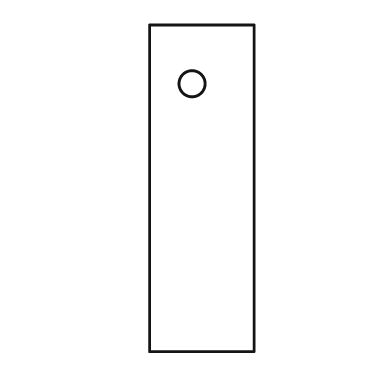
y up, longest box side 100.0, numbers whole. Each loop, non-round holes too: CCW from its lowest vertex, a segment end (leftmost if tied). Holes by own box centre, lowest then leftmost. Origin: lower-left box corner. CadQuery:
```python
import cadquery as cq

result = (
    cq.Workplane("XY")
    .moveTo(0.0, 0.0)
    .lineTo(32.0, 0.0)
    .lineTo(32.0, 100.0)
    .lineTo(0.0, 100.0)
    .close()
    .moveTo(13.0, 82.0)
    .circle(4.0)
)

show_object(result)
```